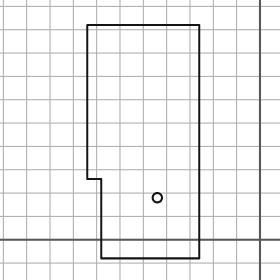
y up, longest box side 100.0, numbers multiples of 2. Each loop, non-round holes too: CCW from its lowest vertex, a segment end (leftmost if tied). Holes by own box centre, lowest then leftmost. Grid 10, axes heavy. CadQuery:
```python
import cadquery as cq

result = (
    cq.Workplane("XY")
    .moveTo(-68.0, -8.0)
    .lineTo(-26.0, -8.0)
    .lineTo(-26.0, 92.0)
    .lineTo(-74.0, 92.0)
    .lineTo(-74.0, 26.0)
    .lineTo(-68.0, 26.0)
    .close()
    .moveTo(-44.0, 18.0)
    .circle(2.0)
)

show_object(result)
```